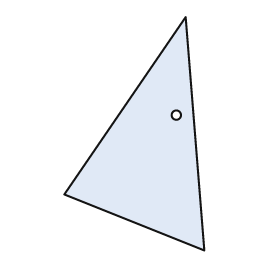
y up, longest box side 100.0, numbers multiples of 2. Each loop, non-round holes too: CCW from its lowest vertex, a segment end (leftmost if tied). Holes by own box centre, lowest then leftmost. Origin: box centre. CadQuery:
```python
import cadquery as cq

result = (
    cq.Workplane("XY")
    .moveTo(30.0, -50.0)
    .lineTo(22.0, 50.0)
    .lineTo(-30.0, -26.0)
    .close()
    .moveTo(18.0, 8.0)
    .circle(2.0)
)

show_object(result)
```